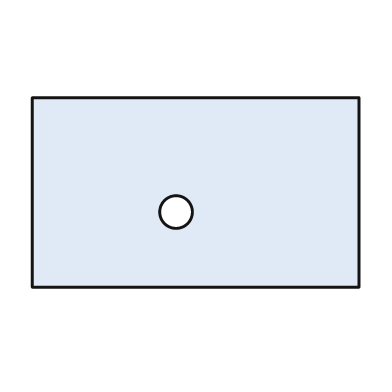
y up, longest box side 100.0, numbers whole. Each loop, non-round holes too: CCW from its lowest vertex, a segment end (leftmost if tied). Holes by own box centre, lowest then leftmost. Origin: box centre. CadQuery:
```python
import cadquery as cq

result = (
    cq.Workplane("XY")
    .moveTo(-50.0, -29.0)
    .lineTo(50.0, -29.0)
    .lineTo(50.0, 29.0)
    .lineTo(-50.0, 29.0)
    .close()
    .moveTo(-6.0, -6.0)
    .circle(5.0)
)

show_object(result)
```